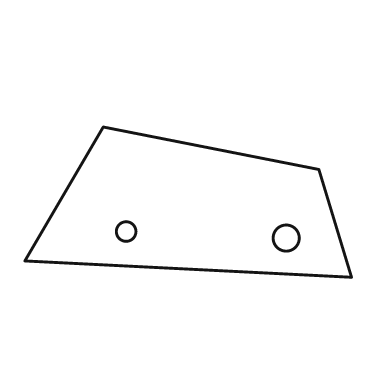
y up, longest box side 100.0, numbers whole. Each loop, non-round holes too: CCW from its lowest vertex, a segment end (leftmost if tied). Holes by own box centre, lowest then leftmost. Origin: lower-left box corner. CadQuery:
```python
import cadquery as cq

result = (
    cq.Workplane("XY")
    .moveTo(100.0, 0.0)
    .lineTo(90.0, 33.0)
    .lineTo(24.0, 46.0)
    .lineTo(0.0, 5.0)
    .close()
    .moveTo(80.0, 12.0)
    .circle(4.0)
    .moveTo(31.0, 14.0)
    .circle(3.0)
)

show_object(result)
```